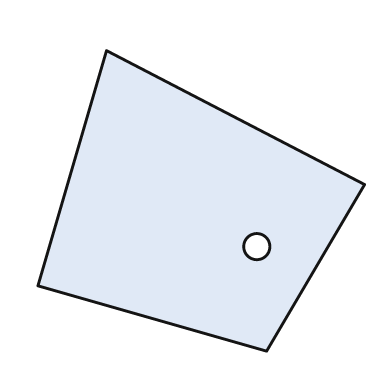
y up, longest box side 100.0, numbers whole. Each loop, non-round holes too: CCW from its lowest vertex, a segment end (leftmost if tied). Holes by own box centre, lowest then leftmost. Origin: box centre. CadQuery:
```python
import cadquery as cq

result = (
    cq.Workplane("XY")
    .moveTo(20.0, -46.0)
    .lineTo(50.0, 5.0)
    .lineTo(-29.0, 46.0)
    .lineTo(-50.0, -26.0)
    .close()
    .moveTo(17.0, -14.0)
    .circle(4.0)
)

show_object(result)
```